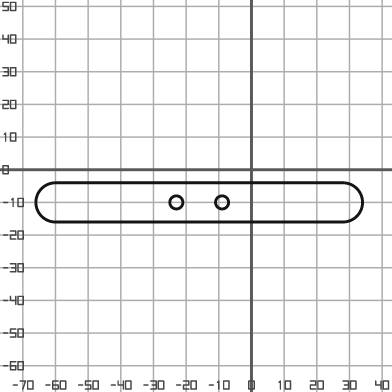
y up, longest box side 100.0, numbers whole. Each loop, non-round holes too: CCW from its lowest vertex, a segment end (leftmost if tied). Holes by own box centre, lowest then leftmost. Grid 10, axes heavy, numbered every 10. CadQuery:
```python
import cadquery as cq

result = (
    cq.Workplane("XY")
    .moveTo(-60.0, -16.0)
    .lineTo(28.0, -16.0)
    .threePointArc((34.0, -10.0), (28.0, -4.0))
    .lineTo(-60.0, -4.0)
    .threePointArc((-66.0, -10.0), (-60.0, -16.0))
    .close()
    .moveTo(-23.0, -10.0)
    .circle(2.0)
    .moveTo(-9.0, -10.0)
    .circle(2.0)
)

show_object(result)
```